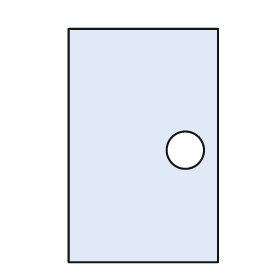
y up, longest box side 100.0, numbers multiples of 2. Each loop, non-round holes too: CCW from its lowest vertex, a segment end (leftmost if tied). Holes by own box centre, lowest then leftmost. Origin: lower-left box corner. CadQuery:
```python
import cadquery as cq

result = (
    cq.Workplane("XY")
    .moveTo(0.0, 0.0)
    .lineTo(64.0, 0.0)
    .lineTo(64.0, 100.0)
    .lineTo(0.0, 100.0)
    .close()
    .moveTo(50.0, 48.0)
    .circle(8.0)
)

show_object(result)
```